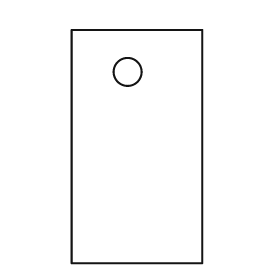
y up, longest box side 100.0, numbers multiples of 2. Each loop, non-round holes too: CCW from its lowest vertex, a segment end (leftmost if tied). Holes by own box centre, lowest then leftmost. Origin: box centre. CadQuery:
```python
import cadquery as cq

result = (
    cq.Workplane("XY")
    .moveTo(-28.0, -50.0)
    .lineTo(28.0, -50.0)
    .lineTo(28.0, 50.0)
    .lineTo(-28.0, 50.0)
    .close()
    .moveTo(-4.0, 32.0)
    .circle(6.0)
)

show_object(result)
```